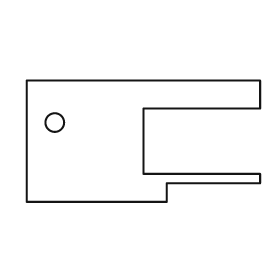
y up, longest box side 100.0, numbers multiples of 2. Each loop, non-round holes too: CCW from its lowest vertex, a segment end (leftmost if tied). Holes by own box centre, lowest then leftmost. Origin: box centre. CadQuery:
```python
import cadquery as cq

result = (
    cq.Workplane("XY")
    .moveTo(-50.0, -26.0)
    .lineTo(10.0, -26.0)
    .lineTo(10.0, -18.0)
    .lineTo(50.0, -18.0)
    .lineTo(50.0, -14.0)
    .lineTo(0.0, -14.0)
    .lineTo(0.0, 14.0)
    .lineTo(50.0, 14.0)
    .lineTo(50.0, 26.0)
    .lineTo(-50.0, 26.0)
    .close()
    .moveTo(-38.0, 8.0)
    .circle(4.0)
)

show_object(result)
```